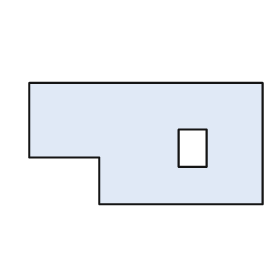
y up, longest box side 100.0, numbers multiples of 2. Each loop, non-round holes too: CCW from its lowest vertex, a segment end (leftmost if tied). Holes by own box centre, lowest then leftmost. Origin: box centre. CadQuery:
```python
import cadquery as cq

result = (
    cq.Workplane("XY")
    .moveTo(-20.0, -26.0)
    .lineTo(50.0, -26.0)
    .lineTo(50.0, 26.0)
    .lineTo(-50.0, 26.0)
    .lineTo(-50.0, -6.0)
    .lineTo(-20.0, -6.0)
    .close()
    .moveTo(14.0, -10.0)
    .lineTo(26.0, -10.0)
    .lineTo(26.0, 6.0)
    .lineTo(14.0, 6.0)
    .close()
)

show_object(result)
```